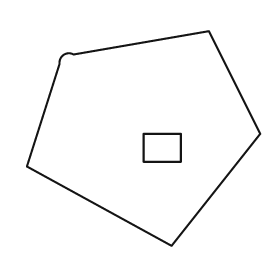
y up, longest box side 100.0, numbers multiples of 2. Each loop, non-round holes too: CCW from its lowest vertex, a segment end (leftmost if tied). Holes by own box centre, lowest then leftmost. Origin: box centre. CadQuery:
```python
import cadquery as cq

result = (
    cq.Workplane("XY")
    .moveTo(12.0, -46.0)
    .lineTo(50.0, 2.0)
    .lineTo(28.0, 46.0)
    .lineTo(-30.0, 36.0)
    .threePointArc((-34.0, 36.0), (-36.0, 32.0))
    .lineTo(-50.0, -12.0)
    .close()
    .moveTo(0.0, -10.0)
    .lineTo(16.0, -10.0)
    .lineTo(16.0, 2.0)
    .lineTo(0.0, 2.0)
    .close()
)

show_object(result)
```